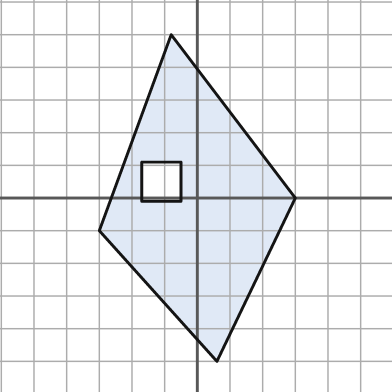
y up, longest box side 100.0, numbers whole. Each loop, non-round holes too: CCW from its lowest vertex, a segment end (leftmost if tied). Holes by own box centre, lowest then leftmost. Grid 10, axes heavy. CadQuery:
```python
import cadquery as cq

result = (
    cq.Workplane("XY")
    .moveTo(6.0, -50.0)
    .lineTo(30.0, 0.0)
    .lineTo(-8.0, 50.0)
    .lineTo(-30.0, -10.0)
    .close()
    .moveTo(-17.0, -1.0)
    .lineTo(-5.0, -1.0)
    .lineTo(-5.0, 11.0)
    .lineTo(-17.0, 11.0)
    .close()
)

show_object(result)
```